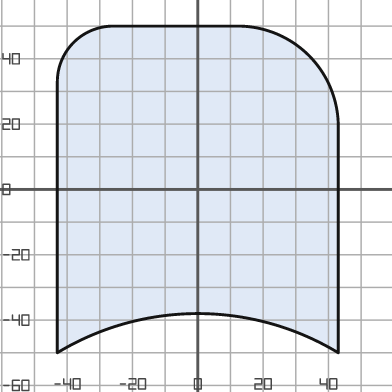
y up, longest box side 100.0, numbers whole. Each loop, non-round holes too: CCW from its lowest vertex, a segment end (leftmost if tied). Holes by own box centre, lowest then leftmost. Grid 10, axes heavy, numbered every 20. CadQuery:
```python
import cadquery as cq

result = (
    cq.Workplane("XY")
    .moveTo(-43.0, -50.0)
    .threePointArc((0.0, -38.0), (43.0, -50.0))
    .lineTo(43.0, 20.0)
    .threePointArc((34.0, 41.0), (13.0, 50.0))
    .lineTo(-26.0, 50.0)
    .threePointArc((-38.0, 45.0), (-43.0, 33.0))
    .close()
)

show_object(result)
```